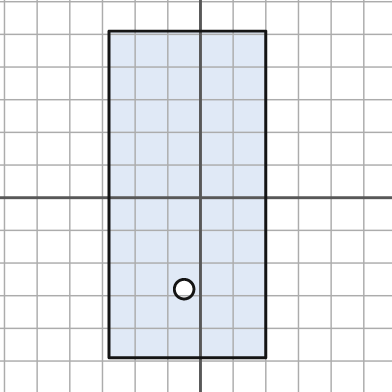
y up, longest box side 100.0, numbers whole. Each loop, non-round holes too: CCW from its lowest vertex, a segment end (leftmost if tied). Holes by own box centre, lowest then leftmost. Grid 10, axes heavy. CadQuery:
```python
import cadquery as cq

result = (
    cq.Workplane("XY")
    .moveTo(-28.0, -49.0)
    .lineTo(20.0, -49.0)
    .lineTo(20.0, 51.0)
    .lineTo(-28.0, 51.0)
    .close()
    .moveTo(-5.0, -28.0)
    .circle(3.0)
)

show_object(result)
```